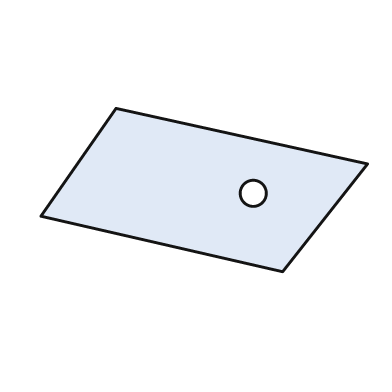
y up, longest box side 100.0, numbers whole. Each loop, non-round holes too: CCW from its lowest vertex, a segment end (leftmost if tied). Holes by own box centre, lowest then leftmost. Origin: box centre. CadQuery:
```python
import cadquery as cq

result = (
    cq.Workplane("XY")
    .moveTo(24.0, -25.0)
    .lineTo(50.0, 8.0)
    .lineTo(-27.0, 25.0)
    .lineTo(-50.0, -8.0)
    .close()
    .moveTo(15.0, -1.0)
    .circle(4.0)
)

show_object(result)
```